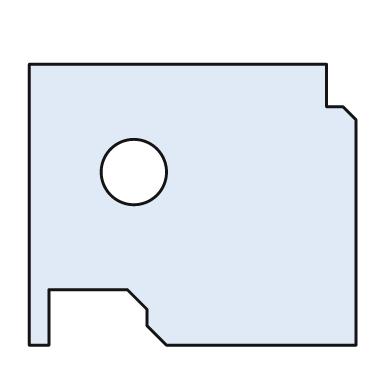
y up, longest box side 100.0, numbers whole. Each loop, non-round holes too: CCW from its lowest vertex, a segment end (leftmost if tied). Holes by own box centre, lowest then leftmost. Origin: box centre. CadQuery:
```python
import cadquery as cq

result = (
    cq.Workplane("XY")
    .moveTo(-50.0, -43.0)
    .lineTo(-44.0, -43.0)
    .lineTo(-44.0, -26.0)
    .lineTo(-20.0, -26.0)
    .lineTo(-14.0, -32.0)
    .lineTo(-14.0, -37.0)
    .lineTo(-8.0, -43.0)
    .lineTo(50.0, -43.0)
    .lineTo(50.0, 26.0)
    .lineTo(46.0, 30.0)
    .lineTo(41.0, 30.0)
    .lineTo(41.0, 43.0)
    .lineTo(-50.0, 43.0)
    .close()
    .moveTo(-18.0, 10.0)
    .circle(10.0)
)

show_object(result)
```